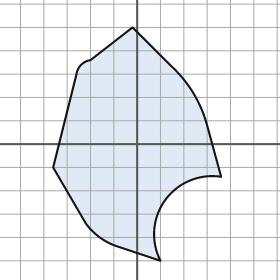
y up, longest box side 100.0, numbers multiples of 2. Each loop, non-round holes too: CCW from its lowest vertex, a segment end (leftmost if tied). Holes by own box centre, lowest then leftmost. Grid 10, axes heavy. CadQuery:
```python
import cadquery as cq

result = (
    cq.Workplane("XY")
    .moveTo(10.0, -50.0)
    .threePointArc((12.0, -24.0), (36.0, -14.0))
    .lineTo(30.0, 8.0)
    .threePointArc((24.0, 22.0), (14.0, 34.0))
    .lineTo(-2.0, 50.0)
    .lineTo(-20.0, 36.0)
    .threePointArc((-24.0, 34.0), (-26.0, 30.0))
    .lineTo(-36.0, -10.0)
    .lineTo(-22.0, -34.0)
    .threePointArc((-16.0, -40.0), (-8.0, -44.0))
    .close()
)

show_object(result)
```